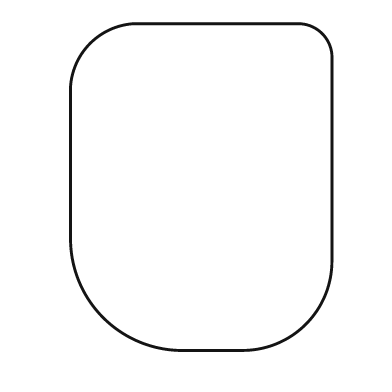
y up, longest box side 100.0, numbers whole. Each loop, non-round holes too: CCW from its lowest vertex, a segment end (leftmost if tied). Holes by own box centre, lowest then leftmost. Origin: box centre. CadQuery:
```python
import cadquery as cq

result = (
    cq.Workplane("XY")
    .moveTo(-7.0, -50.0)
    .lineTo(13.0, -50.0)
    .threePointArc((32.0, -42.0), (40.0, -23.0))
    .lineTo(40.0, 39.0)
    .threePointArc((37.0, 47.0), (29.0, 50.0))
    .lineTo(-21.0, 50.0)
    .threePointArc((-34.0, 44.0), (-40.0, 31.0))
    .lineTo(-40.0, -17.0)
    .threePointArc((-30.0, -40.0), (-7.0, -50.0))
    .close()
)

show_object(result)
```